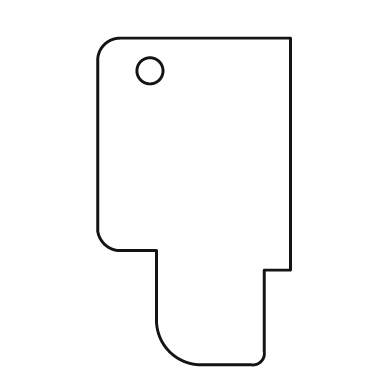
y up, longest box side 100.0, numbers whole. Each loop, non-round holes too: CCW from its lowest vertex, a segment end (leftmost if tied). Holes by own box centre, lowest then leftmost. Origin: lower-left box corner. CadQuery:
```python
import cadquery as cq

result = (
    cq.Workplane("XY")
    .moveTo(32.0, 0.0)
    .lineTo(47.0, 0.0)
    .threePointArc((50.0, 1.0), (51.0, 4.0))
    .lineTo(51.0, 29.0)
    .lineTo(59.0, 29.0)
    .lineTo(59.0, 100.0)
    .lineTo(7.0, 100.0)
    .threePointArc((2.0, 98.0), (0.0, 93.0))
    .lineTo(0.0, 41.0)
    .threePointArc((2.0, 37.0), (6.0, 35.0))
    .lineTo(18.0, 35.0)
    .lineTo(18.0, 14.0)
    .threePointArc((22.0, 4.0), (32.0, 0.0))
    .close()
    .moveTo(16.0, 90.0)
    .circle(4.0)
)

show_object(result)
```